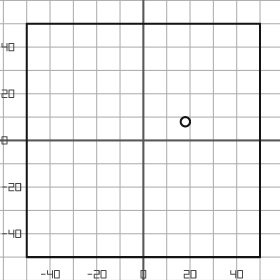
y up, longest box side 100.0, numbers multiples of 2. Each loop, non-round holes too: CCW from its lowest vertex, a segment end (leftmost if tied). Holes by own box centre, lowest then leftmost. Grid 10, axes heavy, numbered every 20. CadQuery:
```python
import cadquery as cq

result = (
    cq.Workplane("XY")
    .moveTo(-50.0, -50.0)
    .lineTo(50.0, -50.0)
    .lineTo(50.0, 50.0)
    .lineTo(-50.0, 50.0)
    .close()
    .moveTo(18.0, 8.0)
    .circle(2.0)
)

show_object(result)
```